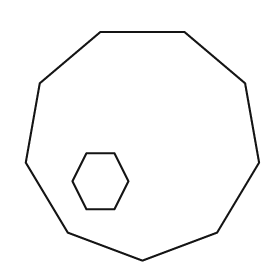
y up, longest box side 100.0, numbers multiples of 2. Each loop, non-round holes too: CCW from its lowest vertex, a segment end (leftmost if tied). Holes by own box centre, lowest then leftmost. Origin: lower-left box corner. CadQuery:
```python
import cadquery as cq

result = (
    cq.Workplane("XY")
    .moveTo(50.0, 0.0)
    .lineTo(82.0, 12.0)
    .lineTo(100.0, 42.0)
    .lineTo(94.0, 76.0)
    .lineTo(68.0, 98.0)
    .lineTo(32.0, 98.0)
    .lineTo(6.0, 76.0)
    .lineTo(0.0, 42.0)
    .lineTo(18.0, 12.0)
    .close()
    .moveTo(26.0, 22.0)
    .lineTo(38.0, 22.0)
    .lineTo(44.0, 34.0)
    .lineTo(38.0, 46.0)
    .lineTo(26.0, 46.0)
    .lineTo(20.0, 34.0)
    .close()
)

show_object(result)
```